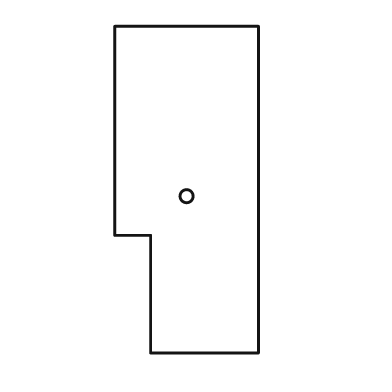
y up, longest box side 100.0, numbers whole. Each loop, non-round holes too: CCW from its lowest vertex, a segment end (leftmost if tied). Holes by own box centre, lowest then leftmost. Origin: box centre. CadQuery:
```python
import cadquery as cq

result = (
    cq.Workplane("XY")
    .moveTo(-11.0, -50.0)
    .lineTo(22.0, -50.0)
    .lineTo(22.0, 50.0)
    .lineTo(-22.0, 50.0)
    .lineTo(-22.0, -14.0)
    .lineTo(-11.0, -14.0)
    .close()
    .moveTo(0.0, -2.0)
    .circle(2.0)
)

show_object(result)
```